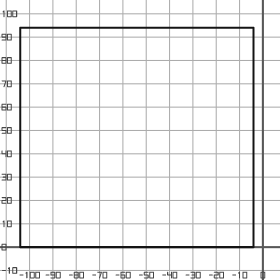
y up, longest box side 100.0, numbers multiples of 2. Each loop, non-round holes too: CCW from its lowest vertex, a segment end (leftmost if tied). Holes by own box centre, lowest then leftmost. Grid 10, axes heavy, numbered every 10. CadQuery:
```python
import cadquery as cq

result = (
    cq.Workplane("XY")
    .moveTo(-104.0, 0.0)
    .lineTo(-4.0, 0.0)
    .lineTo(-4.0, 94.0)
    .lineTo(-104.0, 94.0)
    .close()
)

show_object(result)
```